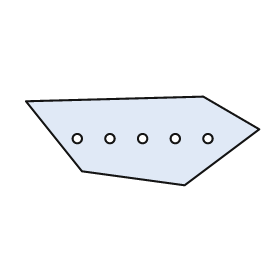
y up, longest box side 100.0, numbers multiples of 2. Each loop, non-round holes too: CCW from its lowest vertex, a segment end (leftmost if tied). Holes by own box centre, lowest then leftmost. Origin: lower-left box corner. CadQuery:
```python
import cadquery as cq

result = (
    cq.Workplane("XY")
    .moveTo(68.0, 0.0)
    .lineTo(100.0, 24.0)
    .lineTo(76.0, 38.0)
    .lineTo(0.0, 36.0)
    .lineTo(24.0, 6.0)
    .close()
    .moveTo(22.0, 20.0)
    .circle(2.0)
    .moveTo(36.0, 20.0)
    .circle(2.0)
    .moveTo(50.0, 20.0)
    .circle(2.0)
    .moveTo(64.0, 20.0)
    .circle(2.0)
    .moveTo(78.0, 20.0)
    .circle(2.0)
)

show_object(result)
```